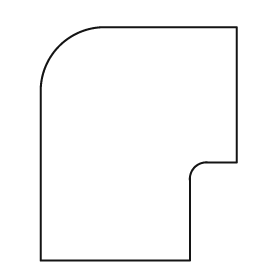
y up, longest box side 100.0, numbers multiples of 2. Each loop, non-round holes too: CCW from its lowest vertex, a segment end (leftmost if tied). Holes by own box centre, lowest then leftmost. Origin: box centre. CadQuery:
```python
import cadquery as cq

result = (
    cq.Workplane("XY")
    .moveTo(-42.0, -50.0)
    .lineTo(22.0, -50.0)
    .lineTo(22.0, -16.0)
    .threePointArc((24.0, -10.0), (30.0, -8.0))
    .lineTo(42.0, -8.0)
    .lineTo(42.0, 50.0)
    .lineTo(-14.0, 50.0)
    .threePointArc((-34.0, 42.0), (-42.0, 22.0))
    .close()
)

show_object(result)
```